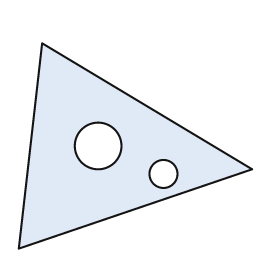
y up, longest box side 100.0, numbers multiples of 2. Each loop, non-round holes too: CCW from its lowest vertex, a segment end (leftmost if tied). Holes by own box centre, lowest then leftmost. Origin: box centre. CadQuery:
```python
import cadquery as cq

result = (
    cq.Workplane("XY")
    .moveTo(-50.0, -44.0)
    .lineTo(50.0, -10.0)
    .lineTo(-40.0, 44.0)
    .close()
    .moveTo(12.0, -12.0)
    .circle(6.0)
    .moveTo(-16.0, 0.0)
    .circle(10.0)
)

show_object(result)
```